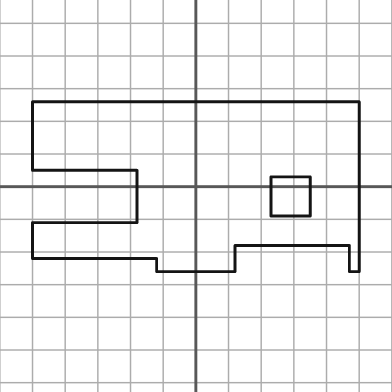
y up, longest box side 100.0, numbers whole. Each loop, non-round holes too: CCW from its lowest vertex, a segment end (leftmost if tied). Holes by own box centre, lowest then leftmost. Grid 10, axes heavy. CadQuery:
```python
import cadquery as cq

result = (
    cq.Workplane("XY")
    .moveTo(-12.0, -26.0)
    .lineTo(12.0, -26.0)
    .lineTo(12.0, -18.0)
    .lineTo(47.0, -18.0)
    .lineTo(47.0, -26.0)
    .lineTo(50.0, -26.0)
    .lineTo(50.0, 26.0)
    .lineTo(-50.0, 26.0)
    .lineTo(-50.0, 5.0)
    .lineTo(-18.0, 5.0)
    .lineTo(-18.0, -11.0)
    .lineTo(-50.0, -11.0)
    .lineTo(-50.0, -22.0)
    .lineTo(-12.0, -22.0)
    .close()
    .moveTo(23.0, -9.0)
    .lineTo(35.0, -9.0)
    .lineTo(35.0, 3.0)
    .lineTo(23.0, 3.0)
    .close()
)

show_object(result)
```